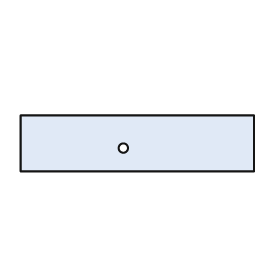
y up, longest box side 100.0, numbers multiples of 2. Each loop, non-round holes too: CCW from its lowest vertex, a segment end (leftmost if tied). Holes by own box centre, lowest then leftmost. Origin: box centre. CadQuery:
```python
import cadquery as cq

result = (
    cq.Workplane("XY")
    .moveTo(-50.0, -12.0)
    .lineTo(50.0, -12.0)
    .lineTo(50.0, 12.0)
    .lineTo(-50.0, 12.0)
    .close()
    .moveTo(-6.0, -2.0)
    .circle(2.0)
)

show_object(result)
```